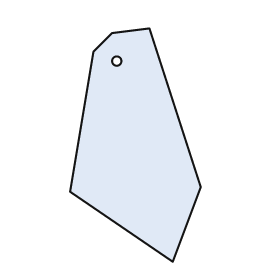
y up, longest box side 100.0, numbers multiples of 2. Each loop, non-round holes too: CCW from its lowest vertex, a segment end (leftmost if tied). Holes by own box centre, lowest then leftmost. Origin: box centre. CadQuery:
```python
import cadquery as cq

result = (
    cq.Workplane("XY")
    .moveTo(16.0, -50.0)
    .lineTo(28.0, -18.0)
    .lineTo(6.0, 50.0)
    .lineTo(-10.0, 48.0)
    .lineTo(-18.0, 40.0)
    .lineTo(-28.0, -20.0)
    .close()
    .moveTo(-8.0, 36.0)
    .circle(2.0)
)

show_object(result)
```